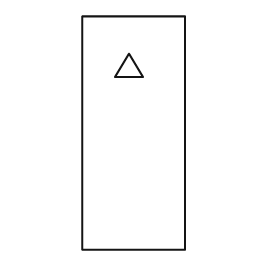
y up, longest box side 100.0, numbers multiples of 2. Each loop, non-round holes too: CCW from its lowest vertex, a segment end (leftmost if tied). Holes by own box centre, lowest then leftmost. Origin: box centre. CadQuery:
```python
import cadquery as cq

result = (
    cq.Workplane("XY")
    .moveTo(-22.0, -50.0)
    .lineTo(22.0, -50.0)
    .lineTo(22.0, 50.0)
    .lineTo(-22.0, 50.0)
    .close()
    .moveTo(-8.0, 24.0)
    .lineTo(4.0, 24.0)
    .lineTo(-2.0, 34.0)
    .close()
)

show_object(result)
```